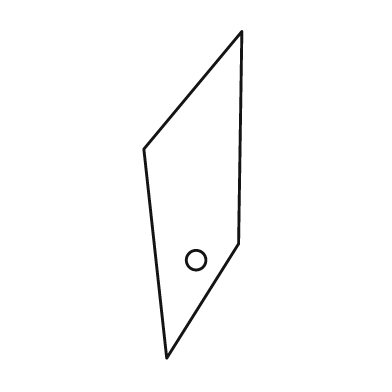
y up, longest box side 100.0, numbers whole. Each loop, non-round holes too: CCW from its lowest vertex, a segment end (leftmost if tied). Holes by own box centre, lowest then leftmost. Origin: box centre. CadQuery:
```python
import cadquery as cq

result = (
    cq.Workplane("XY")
    .moveTo(-8.0, -50.0)
    .lineTo(14.0, -15.0)
    .lineTo(15.0, 50.0)
    .lineTo(-15.0, 14.0)
    .close()
    .moveTo(1.0, -20.0)
    .circle(3.0)
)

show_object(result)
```